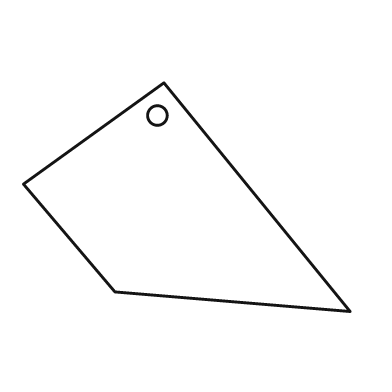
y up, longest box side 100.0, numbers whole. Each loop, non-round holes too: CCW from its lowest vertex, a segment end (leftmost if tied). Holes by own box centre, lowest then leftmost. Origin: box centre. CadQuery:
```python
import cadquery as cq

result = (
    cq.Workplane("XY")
    .moveTo(50.0, -35.0)
    .lineTo(-7.0, 35.0)
    .lineTo(-50.0, 4.0)
    .lineTo(-22.0, -29.0)
    .close()
    .moveTo(-9.0, 25.0)
    .circle(3.0)
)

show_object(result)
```